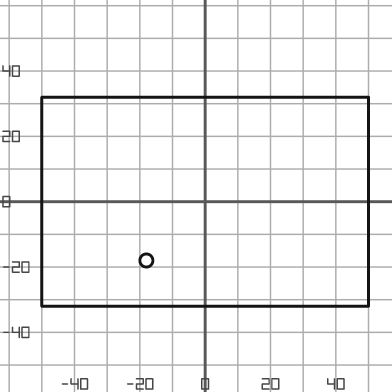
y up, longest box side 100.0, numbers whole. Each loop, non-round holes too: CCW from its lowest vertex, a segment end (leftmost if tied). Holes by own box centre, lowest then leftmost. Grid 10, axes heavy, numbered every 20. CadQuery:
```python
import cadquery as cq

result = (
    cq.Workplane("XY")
    .moveTo(-50.0, -32.0)
    .lineTo(50.0, -32.0)
    .lineTo(50.0, 32.0)
    .lineTo(-50.0, 32.0)
    .close()
    .moveTo(-18.0, -18.0)
    .circle(2.0)
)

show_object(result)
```